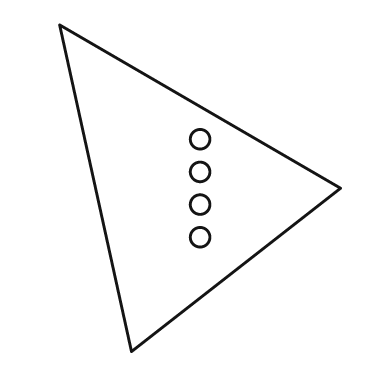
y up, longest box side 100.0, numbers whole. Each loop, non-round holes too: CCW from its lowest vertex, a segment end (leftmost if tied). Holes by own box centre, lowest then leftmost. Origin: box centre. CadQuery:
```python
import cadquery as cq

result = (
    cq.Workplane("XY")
    .moveTo(-21.0, -50.0)
    .lineTo(43.0, 0.0)
    .lineTo(-43.0, 50.0)
    .close()
    .moveTo(0.0, -15.0)
    .circle(3.0)
    .moveTo(0.0, -5.0)
    .circle(3.0)
    .moveTo(0.0, 5.0)
    .circle(3.0)
    .moveTo(0.0, 15.0)
    .circle(3.0)
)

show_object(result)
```